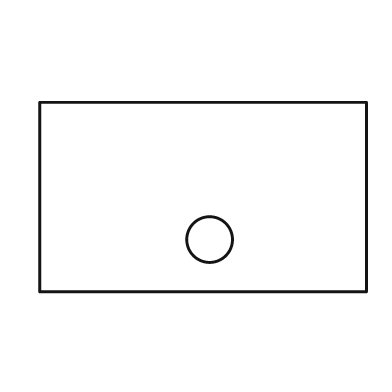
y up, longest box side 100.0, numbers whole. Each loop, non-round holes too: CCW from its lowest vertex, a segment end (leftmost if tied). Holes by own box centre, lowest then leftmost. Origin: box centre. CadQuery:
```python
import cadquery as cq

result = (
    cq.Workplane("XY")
    .moveTo(-50.0, -29.0)
    .lineTo(50.0, -29.0)
    .lineTo(50.0, 29.0)
    .lineTo(-50.0, 29.0)
    .close()
    .moveTo(2.0, -13.0)
    .circle(7.0)
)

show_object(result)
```